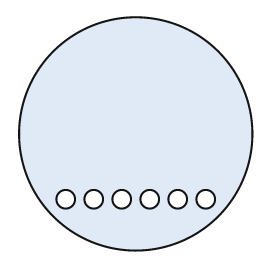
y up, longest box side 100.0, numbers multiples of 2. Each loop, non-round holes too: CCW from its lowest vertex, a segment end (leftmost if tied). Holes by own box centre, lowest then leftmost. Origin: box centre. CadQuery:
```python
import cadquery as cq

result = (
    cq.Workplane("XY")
    .moveTo(0.0, 0.0)
    .circle(50.0)
    .moveTo(-30.0, -28.0)
    .circle(4.0)
    .moveTo(-18.0, -28.0)
    .circle(4.0)
    .moveTo(-6.0, -28.0)
    .circle(4.0)
    .moveTo(6.0, -28.0)
    .circle(4.0)
    .moveTo(18.0, -28.0)
    .circle(4.0)
    .moveTo(30.0, -28.0)
    .circle(4.0)
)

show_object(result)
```